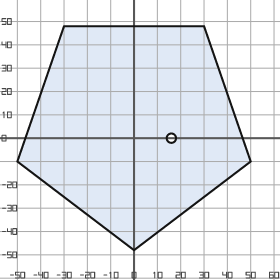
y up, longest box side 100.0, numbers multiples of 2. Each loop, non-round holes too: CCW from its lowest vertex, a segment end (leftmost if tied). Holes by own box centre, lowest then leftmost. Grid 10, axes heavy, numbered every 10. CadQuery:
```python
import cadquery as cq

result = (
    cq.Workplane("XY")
    .moveTo(0.0, -48.0)
    .lineTo(50.0, -10.0)
    .lineTo(30.0, 48.0)
    .lineTo(-30.0, 48.0)
    .lineTo(-50.0, -10.0)
    .close()
    .moveTo(16.0, 0.0)
    .circle(2.0)
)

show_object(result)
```